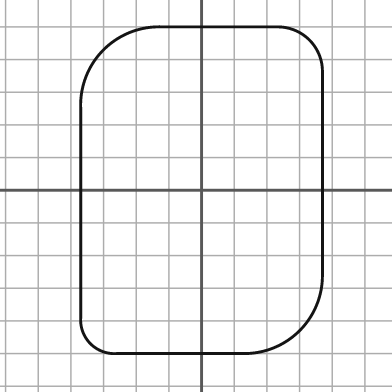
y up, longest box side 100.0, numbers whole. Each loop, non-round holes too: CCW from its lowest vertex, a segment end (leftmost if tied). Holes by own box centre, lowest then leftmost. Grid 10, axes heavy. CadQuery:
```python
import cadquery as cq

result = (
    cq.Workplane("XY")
    .moveTo(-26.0, -50.0)
    .lineTo(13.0, -50.0)
    .threePointArc((30.0, -43.0), (37.0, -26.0))
    .lineTo(37.0, 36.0)
    .threePointArc((33.0, 46.0), (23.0, 50.0))
    .lineTo(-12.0, 50.0)
    .threePointArc((-30.0, 43.0), (-37.0, 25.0))
    .lineTo(-37.0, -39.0)
    .threePointArc((-34.0, -47.0), (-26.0, -50.0))
    .close()
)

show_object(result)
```